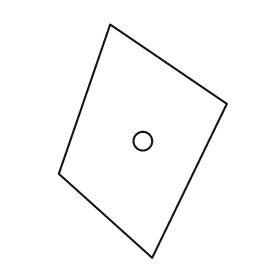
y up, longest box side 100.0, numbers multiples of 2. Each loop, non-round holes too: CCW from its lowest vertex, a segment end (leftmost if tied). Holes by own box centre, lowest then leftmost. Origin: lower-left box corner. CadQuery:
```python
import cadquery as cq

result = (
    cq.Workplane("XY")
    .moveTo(40.0, 0.0)
    .lineTo(72.0, 66.0)
    .lineTo(22.0, 100.0)
    .lineTo(0.0, 36.0)
    .close()
    .moveTo(36.0, 50.0)
    .circle(4.0)
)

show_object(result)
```